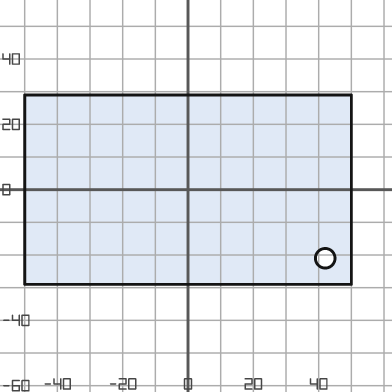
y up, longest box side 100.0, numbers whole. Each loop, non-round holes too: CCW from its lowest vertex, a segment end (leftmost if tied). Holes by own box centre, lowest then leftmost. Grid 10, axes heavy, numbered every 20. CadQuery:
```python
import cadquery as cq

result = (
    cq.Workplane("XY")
    .moveTo(-50.0, -29.0)
    .lineTo(50.0, -29.0)
    .lineTo(50.0, 29.0)
    .lineTo(-50.0, 29.0)
    .close()
    .moveTo(42.0, -21.0)
    .circle(3.0)
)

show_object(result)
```